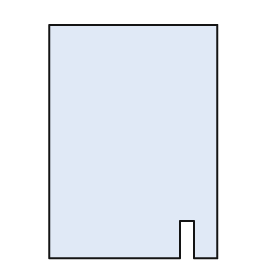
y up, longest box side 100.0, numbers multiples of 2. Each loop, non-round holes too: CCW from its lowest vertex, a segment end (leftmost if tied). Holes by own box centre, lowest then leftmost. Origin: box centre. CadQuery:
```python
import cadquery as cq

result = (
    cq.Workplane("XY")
    .moveTo(-36.0, -50.0)
    .lineTo(20.0, -50.0)
    .lineTo(20.0, -34.0)
    .lineTo(26.0, -34.0)
    .lineTo(26.0, -50.0)
    .lineTo(36.0, -50.0)
    .lineTo(36.0, 50.0)
    .lineTo(-36.0, 50.0)
    .close()
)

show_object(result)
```